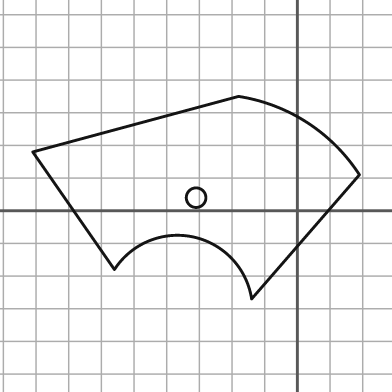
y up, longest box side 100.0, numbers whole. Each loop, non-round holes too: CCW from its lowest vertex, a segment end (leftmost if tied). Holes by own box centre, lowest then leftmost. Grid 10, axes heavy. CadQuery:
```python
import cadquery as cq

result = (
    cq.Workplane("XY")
    .moveTo(-14.0, -27.0)
    .lineTo(19.0, 11.0)
    .threePointArc((3.0, 27.0), (-18.0, 35.0))
    .lineTo(-81.0, 18.0)
    .lineTo(-56.0, -18.0)
    .threePointArc((-32.0, -8.0), (-14.0, -27.0))
    .close()
    .moveTo(-31.0, 4.0)
    .circle(3.0)
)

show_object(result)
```